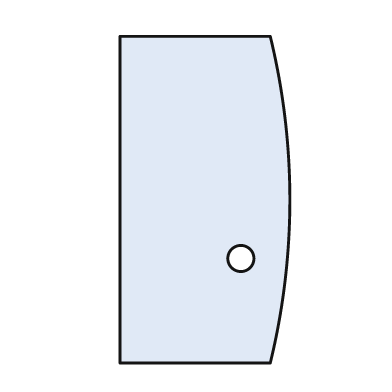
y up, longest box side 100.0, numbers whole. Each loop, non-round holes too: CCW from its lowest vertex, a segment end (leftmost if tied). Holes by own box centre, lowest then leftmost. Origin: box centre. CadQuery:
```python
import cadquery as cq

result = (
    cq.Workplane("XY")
    .moveTo(-26.0, -50.0)
    .lineTo(20.0, -50.0)
    .threePointArc((26.0, 0.0), (20.0, 50.0))
    .lineTo(-26.0, 50.0)
    .close()
    .moveTo(11.0, -18.0)
    .circle(4.0)
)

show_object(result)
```